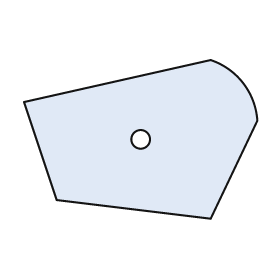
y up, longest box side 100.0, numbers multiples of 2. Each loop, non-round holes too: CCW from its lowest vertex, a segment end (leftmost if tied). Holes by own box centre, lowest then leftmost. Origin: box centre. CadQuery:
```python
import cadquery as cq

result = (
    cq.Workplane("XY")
    .moveTo(30.0, -34.0)
    .lineTo(50.0, 8.0)
    .threePointArc((44.0, 24.0), (30.0, 34.0))
    .lineTo(-50.0, 16.0)
    .lineTo(-36.0, -26.0)
    .close()
    .moveTo(0.0, 0.0)
    .circle(4.0)
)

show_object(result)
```